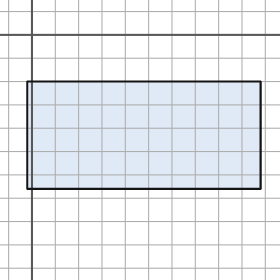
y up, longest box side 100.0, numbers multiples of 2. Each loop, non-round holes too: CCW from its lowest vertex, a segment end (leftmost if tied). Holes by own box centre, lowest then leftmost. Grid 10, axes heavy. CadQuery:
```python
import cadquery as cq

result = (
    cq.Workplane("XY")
    .moveTo(-2.0, -66.0)
    .lineTo(98.0, -66.0)
    .lineTo(98.0, -20.0)
    .lineTo(-2.0, -20.0)
    .close()
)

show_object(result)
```